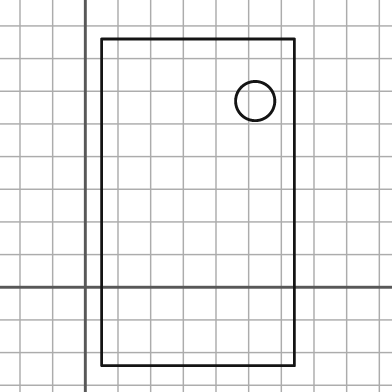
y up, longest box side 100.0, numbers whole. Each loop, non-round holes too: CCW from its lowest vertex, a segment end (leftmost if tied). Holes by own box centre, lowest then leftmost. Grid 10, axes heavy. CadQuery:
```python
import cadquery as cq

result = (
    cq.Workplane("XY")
    .moveTo(5.0, -24.0)
    .lineTo(64.0, -24.0)
    .lineTo(64.0, 76.0)
    .lineTo(5.0, 76.0)
    .close()
    .moveTo(52.0, 57.0)
    .circle(6.0)
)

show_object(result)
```